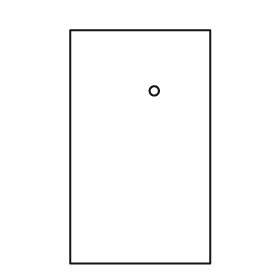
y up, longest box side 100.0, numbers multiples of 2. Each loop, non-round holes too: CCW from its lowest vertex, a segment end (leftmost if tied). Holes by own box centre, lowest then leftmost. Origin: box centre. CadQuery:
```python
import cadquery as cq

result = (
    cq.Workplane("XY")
    .moveTo(-30.0, -50.0)
    .lineTo(30.0, -50.0)
    .lineTo(30.0, 50.0)
    .lineTo(-30.0, 50.0)
    .close()
    .moveTo(6.0, 24.0)
    .circle(2.0)
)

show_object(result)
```